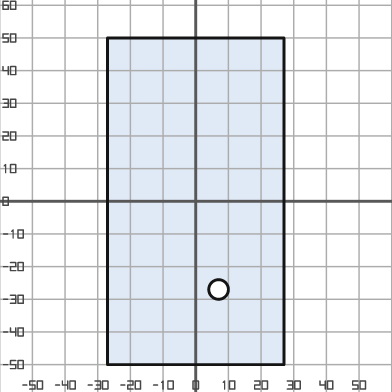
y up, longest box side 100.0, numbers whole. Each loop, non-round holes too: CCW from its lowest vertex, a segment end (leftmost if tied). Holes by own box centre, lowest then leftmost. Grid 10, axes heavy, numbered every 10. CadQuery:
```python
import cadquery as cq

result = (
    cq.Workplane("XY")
    .moveTo(-27.0, -50.0)
    .lineTo(27.0, -50.0)
    .lineTo(27.0, 50.0)
    .lineTo(-27.0, 50.0)
    .close()
    .moveTo(7.0, -27.0)
    .circle(3.0)
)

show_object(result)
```